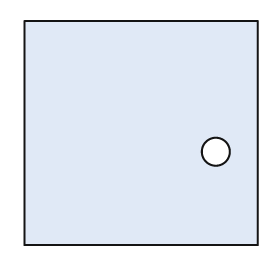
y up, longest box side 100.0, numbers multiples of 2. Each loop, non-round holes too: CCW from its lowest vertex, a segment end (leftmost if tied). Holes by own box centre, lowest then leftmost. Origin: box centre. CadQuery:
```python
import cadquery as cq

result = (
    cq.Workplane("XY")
    .moveTo(-50.0, -48.0)
    .lineTo(50.0, -48.0)
    .lineTo(50.0, 48.0)
    .lineTo(-50.0, 48.0)
    .close()
    .moveTo(32.0, -8.0)
    .circle(6.0)
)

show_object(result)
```